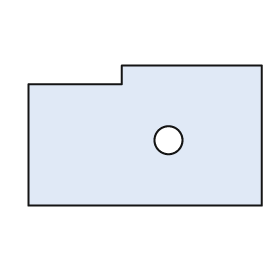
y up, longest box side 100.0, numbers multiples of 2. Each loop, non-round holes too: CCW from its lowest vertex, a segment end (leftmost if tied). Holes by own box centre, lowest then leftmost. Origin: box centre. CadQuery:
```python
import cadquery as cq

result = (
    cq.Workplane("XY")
    .moveTo(-50.0, -30.0)
    .lineTo(50.0, -30.0)
    .lineTo(50.0, 30.0)
    .lineTo(-10.0, 30.0)
    .lineTo(-10.0, 22.0)
    .lineTo(-50.0, 22.0)
    .close()
    .moveTo(10.0, -2.0)
    .circle(6.0)
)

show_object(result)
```